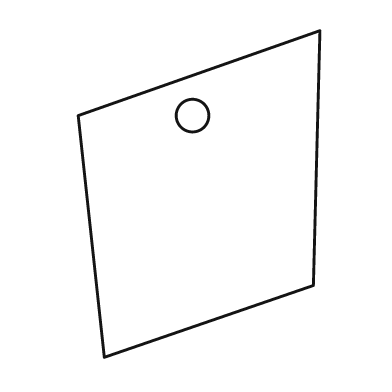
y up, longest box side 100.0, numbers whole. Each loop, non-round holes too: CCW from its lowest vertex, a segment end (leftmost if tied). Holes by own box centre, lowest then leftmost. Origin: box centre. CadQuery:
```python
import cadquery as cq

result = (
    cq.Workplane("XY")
    .moveTo(-29.0, -50.0)
    .lineTo(35.0, -28.0)
    .lineTo(37.0, 50.0)
    .lineTo(-37.0, 24.0)
    .close()
    .moveTo(-2.0, 24.0)
    .circle(5.0)
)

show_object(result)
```